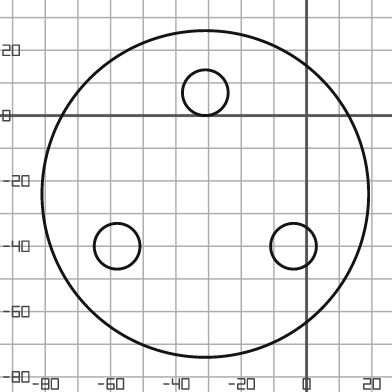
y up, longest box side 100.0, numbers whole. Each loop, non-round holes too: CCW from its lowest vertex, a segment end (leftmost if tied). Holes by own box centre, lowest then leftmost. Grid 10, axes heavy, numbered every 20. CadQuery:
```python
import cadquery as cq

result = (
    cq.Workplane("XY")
    .moveTo(-31.0, -24.0)
    .circle(50.0)
    .moveTo(-58.0, -40.0)
    .circle(7.0)
    .moveTo(-4.0, -40.0)
    .circle(7.0)
    .moveTo(-31.0, 7.0)
    .circle(7.0)
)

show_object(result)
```